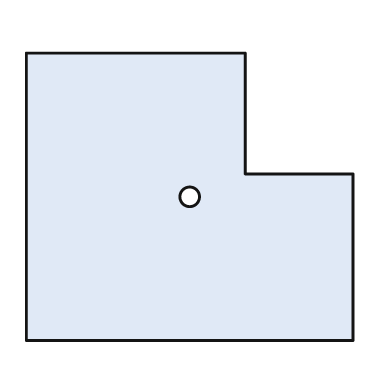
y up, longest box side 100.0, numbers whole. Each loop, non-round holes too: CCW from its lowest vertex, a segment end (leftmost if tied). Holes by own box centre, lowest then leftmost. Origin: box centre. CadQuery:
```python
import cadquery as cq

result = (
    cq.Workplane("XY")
    .moveTo(-50.0, -44.0)
    .lineTo(50.0, -44.0)
    .lineTo(50.0, 7.0)
    .lineTo(17.0, 7.0)
    .lineTo(17.0, 44.0)
    .lineTo(-50.0, 44.0)
    .close()
    .moveTo(0.0, 0.0)
    .circle(3.0)
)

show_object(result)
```